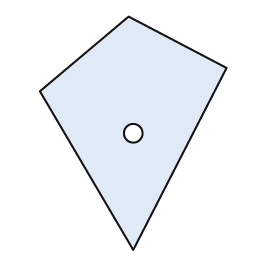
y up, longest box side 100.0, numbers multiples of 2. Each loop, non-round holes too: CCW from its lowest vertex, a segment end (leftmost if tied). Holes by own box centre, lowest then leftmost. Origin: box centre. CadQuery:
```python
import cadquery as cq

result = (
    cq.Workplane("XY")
    .moveTo(0.0, -50.0)
    .lineTo(40.0, 28.0)
    .lineTo(-2.0, 50.0)
    .lineTo(-40.0, 18.0)
    .close()
    .moveTo(0.0, 0.0)
    .circle(4.0)
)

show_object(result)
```